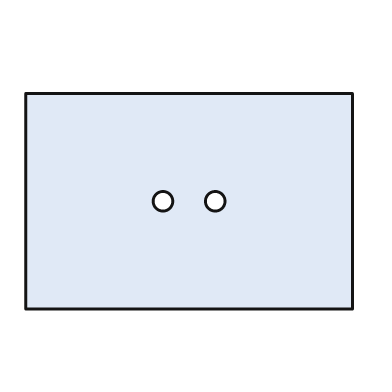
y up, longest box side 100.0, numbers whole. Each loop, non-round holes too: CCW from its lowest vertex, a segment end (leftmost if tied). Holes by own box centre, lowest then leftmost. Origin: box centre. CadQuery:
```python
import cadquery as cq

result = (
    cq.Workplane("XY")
    .moveTo(-50.0, -33.0)
    .lineTo(50.0, -33.0)
    .lineTo(50.0, 33.0)
    .lineTo(-50.0, 33.0)
    .close()
    .moveTo(-8.0, 0.0)
    .circle(3.0)
    .moveTo(8.0, 0.0)
    .circle(3.0)
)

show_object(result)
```